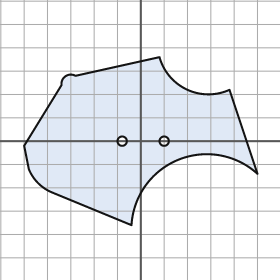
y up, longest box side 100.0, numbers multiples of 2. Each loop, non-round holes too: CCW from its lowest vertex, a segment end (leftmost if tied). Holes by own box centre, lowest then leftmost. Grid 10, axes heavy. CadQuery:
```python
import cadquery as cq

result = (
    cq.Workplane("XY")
    .moveTo(-4.0, -36.0)
    .threePointArc((16.0, -8.0), (50.0, -14.0))
    .lineTo(38.0, 22.0)
    .threePointArc((20.0, 22.0), (8.0, 36.0))
    .lineTo(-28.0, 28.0)
    .threePointArc((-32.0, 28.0), (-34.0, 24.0))
    .lineTo(-50.0, -2.0)
    .lineTo(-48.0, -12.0)
    .threePointArc((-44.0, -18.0), (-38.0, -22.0))
    .close()
    .moveTo(-8.0, 0.0)
    .circle(2.0)
    .moveTo(10.0, 0.0)
    .circle(2.0)
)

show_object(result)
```